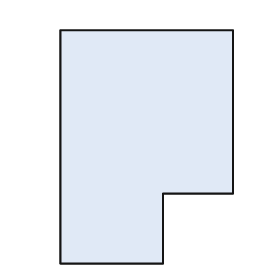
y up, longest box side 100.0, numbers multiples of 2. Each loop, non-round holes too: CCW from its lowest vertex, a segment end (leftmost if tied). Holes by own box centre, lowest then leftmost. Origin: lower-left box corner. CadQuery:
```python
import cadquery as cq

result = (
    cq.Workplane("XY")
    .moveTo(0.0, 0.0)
    .lineTo(44.0, 0.0)
    .lineTo(44.0, 30.0)
    .lineTo(74.0, 30.0)
    .lineTo(74.0, 100.0)
    .lineTo(0.0, 100.0)
    .close()
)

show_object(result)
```